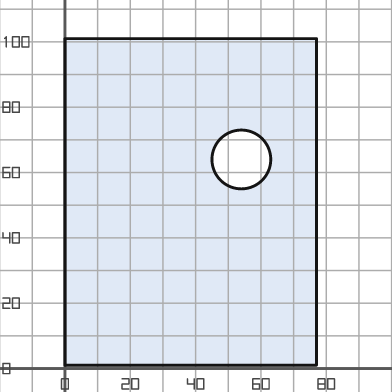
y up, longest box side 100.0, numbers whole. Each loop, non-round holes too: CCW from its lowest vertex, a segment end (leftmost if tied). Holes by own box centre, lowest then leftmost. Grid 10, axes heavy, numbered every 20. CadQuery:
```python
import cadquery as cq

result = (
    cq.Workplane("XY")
    .moveTo(0.0, 1.0)
    .lineTo(77.0, 1.0)
    .lineTo(77.0, 101.0)
    .lineTo(0.0, 101.0)
    .close()
    .moveTo(54.0, 64.0)
    .circle(9.0)
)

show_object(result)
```